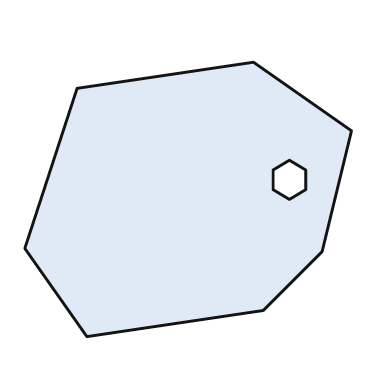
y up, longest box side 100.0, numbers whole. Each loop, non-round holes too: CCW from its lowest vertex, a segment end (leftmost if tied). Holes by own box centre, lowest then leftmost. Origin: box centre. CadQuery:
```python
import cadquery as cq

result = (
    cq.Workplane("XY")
    .moveTo(-31.0, -42.0)
    .lineTo(23.0, -34.0)
    .lineTo(41.0, -16.0)
    .lineTo(50.0, 21.0)
    .lineTo(20.0, 42.0)
    .lineTo(-34.0, 34.0)
    .lineTo(-50.0, -15.0)
    .close()
    .moveTo(31.0, 0.0)
    .lineTo(36.0, 3.0)
    .lineTo(36.0, 9.0)
    .lineTo(31.0, 12.0)
    .lineTo(26.0, 9.0)
    .lineTo(26.0, 3.0)
    .close()
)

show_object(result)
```